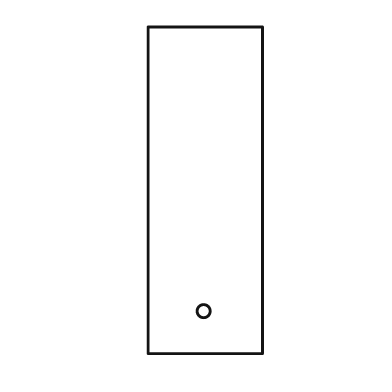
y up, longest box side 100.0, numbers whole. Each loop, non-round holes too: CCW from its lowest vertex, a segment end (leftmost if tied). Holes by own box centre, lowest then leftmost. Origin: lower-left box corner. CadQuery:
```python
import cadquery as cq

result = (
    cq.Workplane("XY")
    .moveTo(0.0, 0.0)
    .lineTo(35.0, 0.0)
    .lineTo(35.0, 100.0)
    .lineTo(0.0, 100.0)
    .close()
    .moveTo(17.0, 13.0)
    .circle(2.0)
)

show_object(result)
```